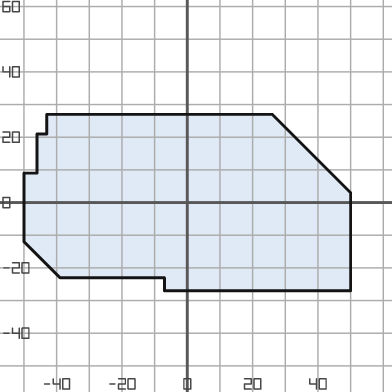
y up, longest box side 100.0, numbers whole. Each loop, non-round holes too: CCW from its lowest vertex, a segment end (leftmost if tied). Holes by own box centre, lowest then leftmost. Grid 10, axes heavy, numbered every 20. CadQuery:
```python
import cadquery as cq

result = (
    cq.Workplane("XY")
    .moveTo(-7.0, -27.0)
    .lineTo(50.0, -27.0)
    .lineTo(50.0, 3.0)
    .lineTo(26.0, 27.0)
    .lineTo(-43.0, 27.0)
    .lineTo(-43.0, 21.0)
    .lineTo(-46.0, 21.0)
    .lineTo(-46.0, 9.0)
    .lineTo(-50.0, 9.0)
    .lineTo(-50.0, -12.0)
    .lineTo(-39.0, -23.0)
    .lineTo(-7.0, -23.0)
    .close()
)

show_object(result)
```